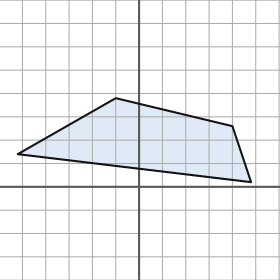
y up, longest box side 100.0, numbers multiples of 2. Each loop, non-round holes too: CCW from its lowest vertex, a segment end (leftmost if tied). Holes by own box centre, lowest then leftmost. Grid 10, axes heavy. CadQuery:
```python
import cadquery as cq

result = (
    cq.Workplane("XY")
    .moveTo(48.0, 2.0)
    .lineTo(40.0, 26.0)
    .lineTo(-10.0, 38.0)
    .lineTo(-52.0, 14.0)
    .close()
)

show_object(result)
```